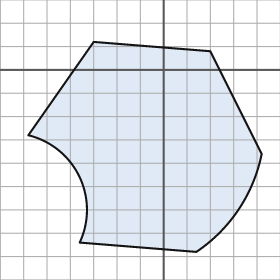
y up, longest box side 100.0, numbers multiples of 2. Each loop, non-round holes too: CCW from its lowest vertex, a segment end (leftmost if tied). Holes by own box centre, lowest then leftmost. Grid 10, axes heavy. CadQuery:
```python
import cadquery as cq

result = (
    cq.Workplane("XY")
    .moveTo(14.0, -78.0)
    .threePointArc((32.0, -60.0), (42.0, -36.0))
    .lineTo(20.0, 8.0)
    .lineTo(-30.0, 12.0)
    .lineTo(-58.0, -28.0)
    .threePointArc((-36.0, -46.0), (-36.0, -74.0))
    .close()
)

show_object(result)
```